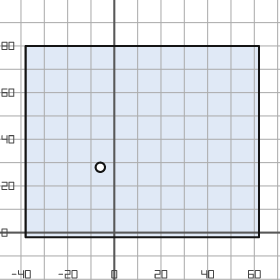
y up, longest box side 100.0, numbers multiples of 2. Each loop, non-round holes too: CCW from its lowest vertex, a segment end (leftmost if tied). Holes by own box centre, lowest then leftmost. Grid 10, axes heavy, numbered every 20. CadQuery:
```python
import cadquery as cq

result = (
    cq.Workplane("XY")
    .moveTo(-38.0, -2.0)
    .lineTo(62.0, -2.0)
    .lineTo(62.0, 80.0)
    .lineTo(-38.0, 80.0)
    .close()
    .moveTo(-6.0, 28.0)
    .circle(2.0)
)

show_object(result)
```